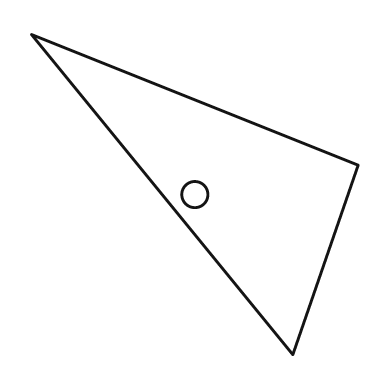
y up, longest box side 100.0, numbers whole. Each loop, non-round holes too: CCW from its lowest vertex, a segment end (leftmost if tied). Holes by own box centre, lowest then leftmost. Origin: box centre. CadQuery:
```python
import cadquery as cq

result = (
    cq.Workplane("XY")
    .moveTo(30.0, -49.0)
    .lineTo(50.0, 9.0)
    .lineTo(-50.0, 49.0)
    .close()
    .moveTo(0.0, 0.0)
    .circle(4.0)
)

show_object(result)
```